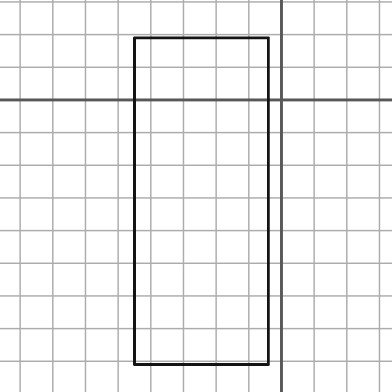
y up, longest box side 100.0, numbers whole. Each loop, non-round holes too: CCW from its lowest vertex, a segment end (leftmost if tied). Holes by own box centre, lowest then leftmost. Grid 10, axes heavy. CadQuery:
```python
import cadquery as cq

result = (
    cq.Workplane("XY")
    .moveTo(-45.0, -81.0)
    .lineTo(-4.0, -81.0)
    .lineTo(-4.0, 19.0)
    .lineTo(-45.0, 19.0)
    .close()
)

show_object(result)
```